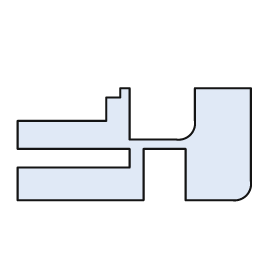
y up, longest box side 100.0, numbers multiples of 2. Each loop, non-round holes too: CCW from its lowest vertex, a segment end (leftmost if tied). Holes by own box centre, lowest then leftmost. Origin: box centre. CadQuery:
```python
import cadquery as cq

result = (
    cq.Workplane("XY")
    .moveTo(-50.0, -24.0)
    .lineTo(4.0, -24.0)
    .lineTo(4.0, -2.0)
    .lineTo(22.0, -2.0)
    .lineTo(22.0, -24.0)
    .lineTo(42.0, -24.0)
    .threePointArc((48.0, -22.0), (50.0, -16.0))
    .lineTo(50.0, 24.0)
    .lineTo(26.0, 24.0)
    .lineTo(26.0, 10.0)
    .threePointArc((24.0, 4.0), (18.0, 2.0))
    .lineTo(-2.0, 2.0)
    .lineTo(-2.0, 24.0)
    .lineTo(-6.0, 24.0)
    .lineTo(-6.0, 20.0)
    .lineTo(-12.0, 20.0)
    .lineTo(-12.0, 10.0)
    .lineTo(-50.0, 10.0)
    .lineTo(-50.0, -2.0)
    .lineTo(-2.0, -2.0)
    .lineTo(-2.0, -10.0)
    .lineTo(-50.0, -10.0)
    .close()
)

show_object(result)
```